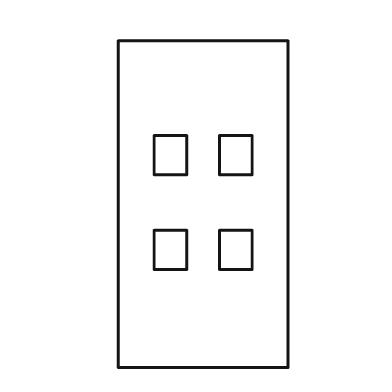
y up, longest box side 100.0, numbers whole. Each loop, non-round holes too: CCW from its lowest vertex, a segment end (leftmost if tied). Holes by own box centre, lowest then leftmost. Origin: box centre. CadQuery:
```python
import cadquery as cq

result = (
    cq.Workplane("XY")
    .moveTo(-26.0, -50.0)
    .lineTo(26.0, -50.0)
    .lineTo(26.0, 50.0)
    .lineTo(-26.0, 50.0)
    .close()
    .moveTo(-15.0, -20.0)
    .lineTo(-5.0, -20.0)
    .lineTo(-5.0, -8.0)
    .lineTo(-15.0, -8.0)
    .close()
    .moveTo(5.0, -20.0)
    .lineTo(15.0, -20.0)
    .lineTo(15.0, -8.0)
    .lineTo(5.0, -8.0)
    .close()
    .moveTo(-15.0, 9.0)
    .lineTo(-5.0, 9.0)
    .lineTo(-5.0, 21.0)
    .lineTo(-15.0, 21.0)
    .close()
    .moveTo(5.0, 9.0)
    .lineTo(15.0, 9.0)
    .lineTo(15.0, 21.0)
    .lineTo(5.0, 21.0)
    .close()
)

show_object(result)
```